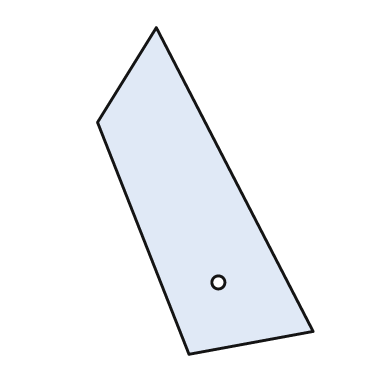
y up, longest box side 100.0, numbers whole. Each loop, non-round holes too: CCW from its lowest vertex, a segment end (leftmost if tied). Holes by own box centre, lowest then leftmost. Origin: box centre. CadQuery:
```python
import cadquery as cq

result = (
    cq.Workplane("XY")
    .moveTo(-5.0, -50.0)
    .lineTo(33.0, -43.0)
    .lineTo(-15.0, 50.0)
    .lineTo(-33.0, 21.0)
    .close()
    .moveTo(4.0, -28.0)
    .circle(2.0)
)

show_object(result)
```